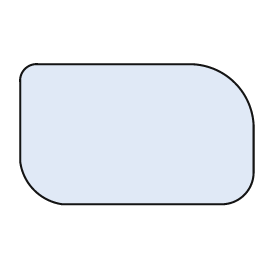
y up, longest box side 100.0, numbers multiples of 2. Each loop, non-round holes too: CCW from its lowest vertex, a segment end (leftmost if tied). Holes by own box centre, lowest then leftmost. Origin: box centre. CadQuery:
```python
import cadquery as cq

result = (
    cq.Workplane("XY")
    .moveTo(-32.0, -30.0)
    .lineTo(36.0, -30.0)
    .threePointArc((46.0, -26.0), (50.0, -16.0))
    .lineTo(50.0, 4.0)
    .threePointArc((42.0, 22.0), (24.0, 30.0))
    .lineTo(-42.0, 30.0)
    .threePointArc((-48.0, 28.0), (-50.0, 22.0))
    .lineTo(-50.0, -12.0)
    .threePointArc((-44.0, -24.0), (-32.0, -30.0))
    .close()
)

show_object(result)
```